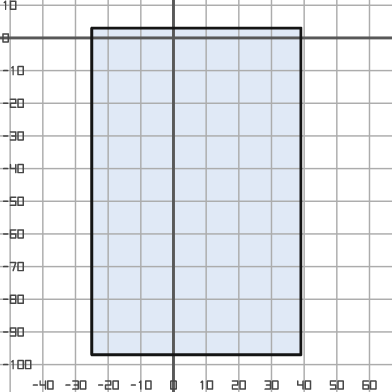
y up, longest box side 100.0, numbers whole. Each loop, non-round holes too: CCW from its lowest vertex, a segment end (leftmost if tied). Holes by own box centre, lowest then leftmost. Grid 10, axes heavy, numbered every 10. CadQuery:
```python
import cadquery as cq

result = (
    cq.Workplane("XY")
    .moveTo(-25.0, -97.0)
    .lineTo(39.0, -97.0)
    .lineTo(39.0, 3.0)
    .lineTo(-25.0, 3.0)
    .close()
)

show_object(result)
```